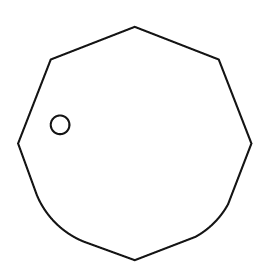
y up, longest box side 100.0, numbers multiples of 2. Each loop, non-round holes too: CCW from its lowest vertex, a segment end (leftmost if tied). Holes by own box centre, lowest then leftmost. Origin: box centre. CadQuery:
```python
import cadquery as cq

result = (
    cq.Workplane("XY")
    .moveTo(0.0, -50.0)
    .lineTo(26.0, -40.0)
    .threePointArc((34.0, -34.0), (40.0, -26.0))
    .lineTo(50.0, 0.0)
    .lineTo(36.0, 36.0)
    .lineTo(0.0, 50.0)
    .lineTo(-36.0, 36.0)
    .lineTo(-50.0, 0.0)
    .lineTo(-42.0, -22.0)
    .threePointArc((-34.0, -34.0), (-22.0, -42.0))
    .close()
    .moveTo(-32.0, 8.0)
    .circle(4.0)
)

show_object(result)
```